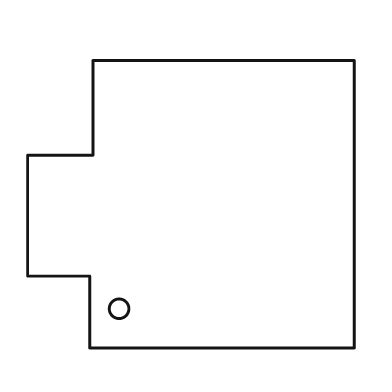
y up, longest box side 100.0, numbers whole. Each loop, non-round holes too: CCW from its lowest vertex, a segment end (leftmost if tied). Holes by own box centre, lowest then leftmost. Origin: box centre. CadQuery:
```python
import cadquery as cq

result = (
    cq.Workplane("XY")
    .moveTo(-31.0, -44.0)
    .lineTo(50.0, -44.0)
    .lineTo(50.0, 44.0)
    .lineTo(-30.0, 44.0)
    .lineTo(-30.0, 15.0)
    .lineTo(-50.0, 15.0)
    .lineTo(-50.0, -22.0)
    .lineTo(-31.0, -22.0)
    .close()
    .moveTo(-22.0, -32.0)
    .circle(3.0)
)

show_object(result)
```